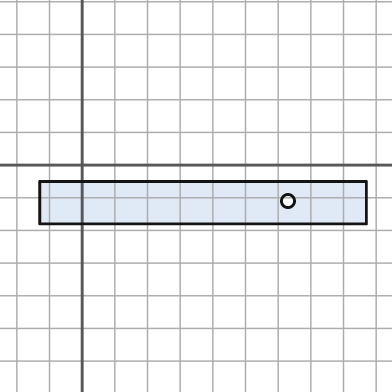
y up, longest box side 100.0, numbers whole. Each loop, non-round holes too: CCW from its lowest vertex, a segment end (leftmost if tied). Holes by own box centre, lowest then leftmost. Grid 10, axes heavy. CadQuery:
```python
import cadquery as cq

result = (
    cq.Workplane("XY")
    .moveTo(-13.0, -18.0)
    .lineTo(87.0, -18.0)
    .lineTo(87.0, -5.0)
    .lineTo(-13.0, -5.0)
    .close()
    .moveTo(63.0, -11.0)
    .circle(2.0)
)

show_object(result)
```